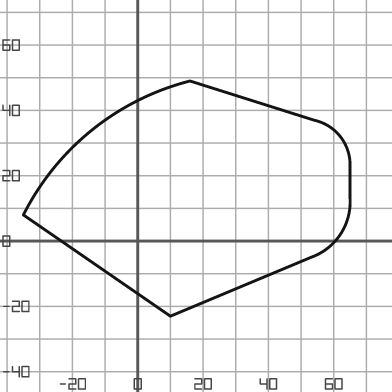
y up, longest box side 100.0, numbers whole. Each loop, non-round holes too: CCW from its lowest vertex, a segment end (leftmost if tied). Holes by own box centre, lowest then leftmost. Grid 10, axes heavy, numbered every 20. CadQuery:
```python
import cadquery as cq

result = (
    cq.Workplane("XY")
    .moveTo(10.0, -23.0)
    .lineTo(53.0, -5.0)
    .threePointArc((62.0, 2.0), (65.0, 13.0))
    .lineTo(65.0, 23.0)
    .threePointArc((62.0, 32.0), (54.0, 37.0))
    .lineTo(16.0, 49.0)
    .threePointArc((-14.0, 34.0), (-35.0, 8.0))
    .close()
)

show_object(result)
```